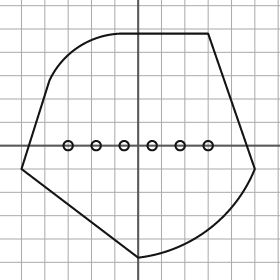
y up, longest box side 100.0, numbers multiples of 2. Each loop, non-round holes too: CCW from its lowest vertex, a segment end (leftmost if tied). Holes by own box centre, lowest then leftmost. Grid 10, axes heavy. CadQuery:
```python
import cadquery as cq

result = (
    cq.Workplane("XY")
    .moveTo(0.0, -48.0)
    .threePointArc((30.0, -36.0), (50.0, -10.0))
    .lineTo(30.0, 48.0)
    .lineTo(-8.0, 48.0)
    .threePointArc((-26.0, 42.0), (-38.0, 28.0))
    .lineTo(-50.0, -10.0)
    .close()
    .moveTo(-30.0, 0.0)
    .circle(2.0)
    .moveTo(-18.0, 0.0)
    .circle(2.0)
    .moveTo(-6.0, 0.0)
    .circle(2.0)
    .moveTo(6.0, 0.0)
    .circle(2.0)
    .moveTo(18.0, 0.0)
    .circle(2.0)
    .moveTo(30.0, 0.0)
    .circle(2.0)
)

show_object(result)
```